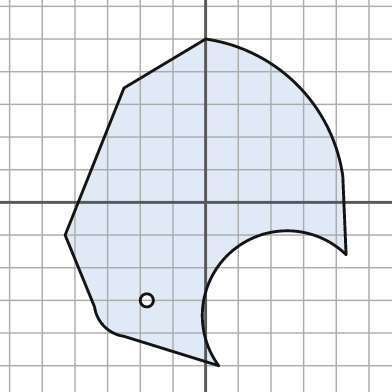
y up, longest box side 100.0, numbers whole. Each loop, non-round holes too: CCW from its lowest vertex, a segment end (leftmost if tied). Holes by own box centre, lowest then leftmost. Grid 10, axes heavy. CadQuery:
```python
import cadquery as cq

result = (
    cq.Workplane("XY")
    .moveTo(4.0, -50.0)
    .threePointArc((8.0, -15.0), (43.0, -16.0))
    .lineTo(42.0, 8.0)
    .threePointArc((28.0, 36.0), (0.0, 50.0))
    .lineTo(-25.0, 35.0)
    .lineTo(-43.0, -10.0)
    .lineTo(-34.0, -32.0)
    .threePointArc((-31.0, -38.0), (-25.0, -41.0))
    .close()
    .moveTo(-18.0, -30.0)
    .circle(2.0)
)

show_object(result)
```